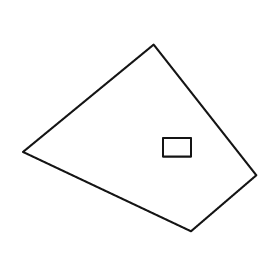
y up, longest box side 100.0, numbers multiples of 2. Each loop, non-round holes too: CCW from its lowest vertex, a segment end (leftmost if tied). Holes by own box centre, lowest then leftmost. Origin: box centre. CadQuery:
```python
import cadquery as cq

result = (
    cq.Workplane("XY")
    .moveTo(22.0, -40.0)
    .lineTo(50.0, -16.0)
    .lineTo(6.0, 40.0)
    .lineTo(-50.0, -6.0)
    .close()
    .moveTo(10.0, -8.0)
    .lineTo(22.0, -8.0)
    .lineTo(22.0, 0.0)
    .lineTo(10.0, 0.0)
    .close()
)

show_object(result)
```